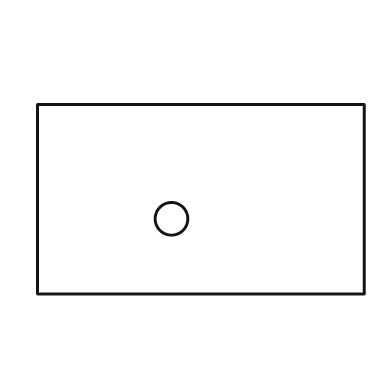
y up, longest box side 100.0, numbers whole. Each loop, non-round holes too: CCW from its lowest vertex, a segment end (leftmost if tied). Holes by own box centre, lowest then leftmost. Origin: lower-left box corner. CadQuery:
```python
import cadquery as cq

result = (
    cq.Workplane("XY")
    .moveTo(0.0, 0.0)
    .lineTo(100.0, 0.0)
    .lineTo(100.0, 58.0)
    .lineTo(0.0, 58.0)
    .close()
    .moveTo(41.0, 23.0)
    .circle(5.0)
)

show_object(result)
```